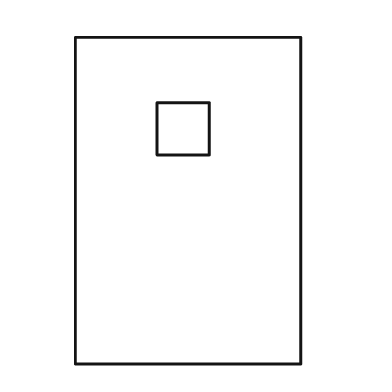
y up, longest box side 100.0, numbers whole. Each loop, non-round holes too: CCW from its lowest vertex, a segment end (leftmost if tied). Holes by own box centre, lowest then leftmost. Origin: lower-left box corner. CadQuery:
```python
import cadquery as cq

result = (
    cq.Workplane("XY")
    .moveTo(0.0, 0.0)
    .lineTo(69.0, 0.0)
    .lineTo(69.0, 100.0)
    .lineTo(0.0, 100.0)
    .close()
    .moveTo(25.0, 64.0)
    .lineTo(41.0, 64.0)
    .lineTo(41.0, 80.0)
    .lineTo(25.0, 80.0)
    .close()
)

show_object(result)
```